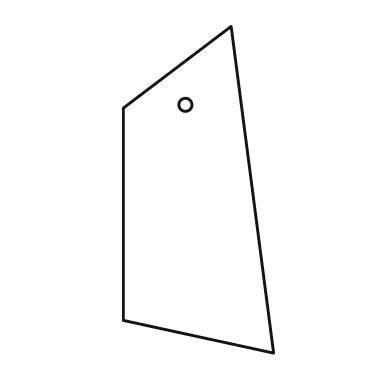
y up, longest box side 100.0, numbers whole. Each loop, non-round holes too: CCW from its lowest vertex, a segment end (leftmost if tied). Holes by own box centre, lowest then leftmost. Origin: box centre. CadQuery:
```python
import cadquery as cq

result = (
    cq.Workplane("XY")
    .moveTo(23.0, -50.0)
    .lineTo(10.0, 50.0)
    .lineTo(-23.0, 25.0)
    .lineTo(-23.0, -40.0)
    .close()
    .moveTo(-4.0, 26.0)
    .circle(2.0)
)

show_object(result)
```